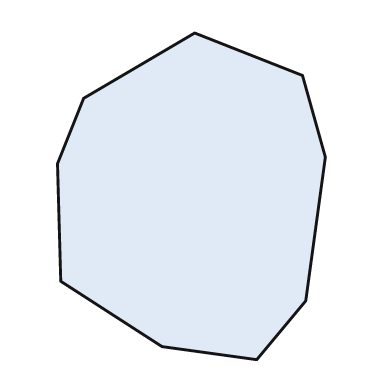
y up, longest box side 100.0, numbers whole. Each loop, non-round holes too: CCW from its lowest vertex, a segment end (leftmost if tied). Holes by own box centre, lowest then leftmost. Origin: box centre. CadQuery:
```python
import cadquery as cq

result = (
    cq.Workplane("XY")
    .moveTo(20.0, -50.0)
    .lineTo(35.0, -32.0)
    .lineTo(41.0, 12.0)
    .lineTo(34.0, 37.0)
    .lineTo(1.0, 50.0)
    .lineTo(-33.0, 30.0)
    .lineTo(-41.0, 10.0)
    .lineTo(-40.0, -26.0)
    .lineTo(-9.0, -46.0)
    .close()
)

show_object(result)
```